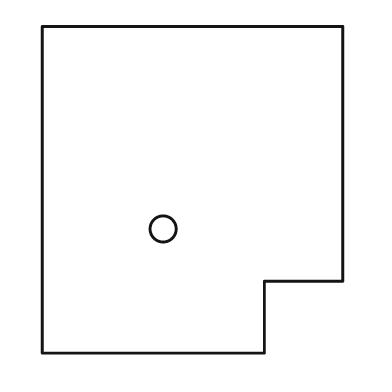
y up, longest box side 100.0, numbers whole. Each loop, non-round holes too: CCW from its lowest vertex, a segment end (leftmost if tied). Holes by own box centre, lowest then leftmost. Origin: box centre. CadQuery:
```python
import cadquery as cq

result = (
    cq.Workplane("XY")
    .moveTo(-46.0, -50.0)
    .lineTo(22.0, -50.0)
    .lineTo(22.0, -28.0)
    .lineTo(46.0, -28.0)
    .lineTo(46.0, 50.0)
    .lineTo(-46.0, 50.0)
    .close()
    .moveTo(-9.0, -12.0)
    .circle(4.0)
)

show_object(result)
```